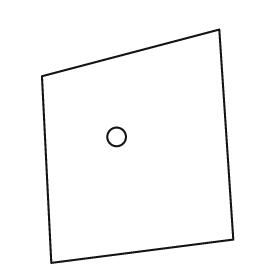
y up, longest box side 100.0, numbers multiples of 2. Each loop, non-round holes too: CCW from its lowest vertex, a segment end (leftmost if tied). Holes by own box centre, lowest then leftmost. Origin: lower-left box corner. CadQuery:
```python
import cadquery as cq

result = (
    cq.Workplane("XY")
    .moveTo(4.0, 0.0)
    .lineTo(82.0, 10.0)
    .lineTo(76.0, 100.0)
    .lineTo(0.0, 80.0)
    .close()
    .moveTo(32.0, 54.0)
    .circle(4.0)
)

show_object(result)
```